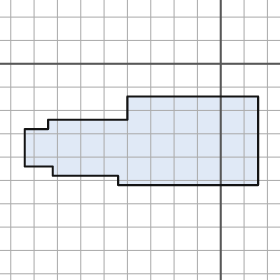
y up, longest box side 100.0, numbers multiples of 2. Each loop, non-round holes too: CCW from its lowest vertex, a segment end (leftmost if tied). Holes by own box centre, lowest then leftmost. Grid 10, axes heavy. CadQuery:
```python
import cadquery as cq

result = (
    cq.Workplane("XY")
    .moveTo(-44.0, -52.0)
    .lineTo(16.0, -52.0)
    .lineTo(16.0, -14.0)
    .lineTo(-40.0, -14.0)
    .lineTo(-40.0, -24.0)
    .lineTo(-74.0, -24.0)
    .lineTo(-74.0, -28.0)
    .lineTo(-84.0, -28.0)
    .lineTo(-84.0, -44.0)
    .lineTo(-72.0, -44.0)
    .lineTo(-72.0, -48.0)
    .lineTo(-44.0, -48.0)
    .close()
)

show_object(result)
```